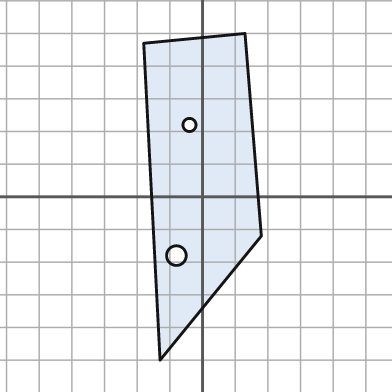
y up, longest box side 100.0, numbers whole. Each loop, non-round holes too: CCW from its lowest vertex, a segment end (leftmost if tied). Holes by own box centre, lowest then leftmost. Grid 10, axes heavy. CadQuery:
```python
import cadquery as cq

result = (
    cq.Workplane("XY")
    .moveTo(-13.0, -50.0)
    .lineTo(18.0, -12.0)
    .lineTo(13.0, 50.0)
    .lineTo(-18.0, 47.0)
    .close()
    .moveTo(-8.0, -18.0)
    .circle(3.0)
    .moveTo(-4.0, 22.0)
    .circle(2.0)
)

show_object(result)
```